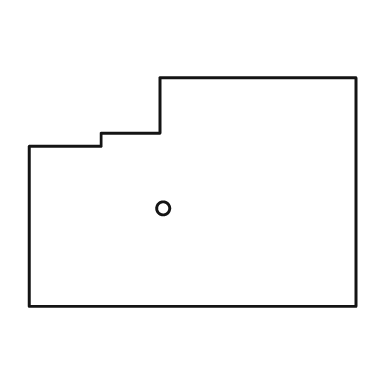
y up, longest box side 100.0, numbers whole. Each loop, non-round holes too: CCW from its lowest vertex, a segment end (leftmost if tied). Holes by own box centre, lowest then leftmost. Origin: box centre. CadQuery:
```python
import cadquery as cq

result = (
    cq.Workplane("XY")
    .moveTo(-50.0, -35.0)
    .lineTo(50.0, -35.0)
    .lineTo(50.0, 35.0)
    .lineTo(-10.0, 35.0)
    .lineTo(-10.0, 18.0)
    .lineTo(-28.0, 18.0)
    .lineTo(-28.0, 14.0)
    .lineTo(-50.0, 14.0)
    .close()
    .moveTo(-9.0, -5.0)
    .circle(2.0)
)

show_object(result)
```